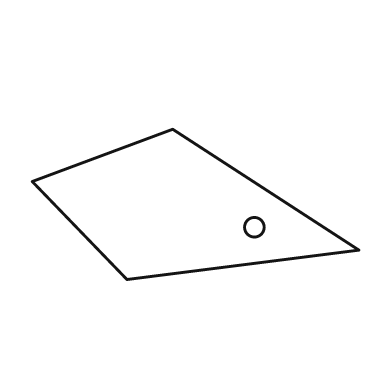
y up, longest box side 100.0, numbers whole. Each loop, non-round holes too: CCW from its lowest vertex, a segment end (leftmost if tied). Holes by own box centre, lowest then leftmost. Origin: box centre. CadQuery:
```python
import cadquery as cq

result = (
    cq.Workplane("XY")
    .moveTo(-21.0, -23.0)
    .lineTo(50.0, -14.0)
    .lineTo(-7.0, 23.0)
    .lineTo(-50.0, 7.0)
    .close()
    .moveTo(18.0, -7.0)
    .circle(3.0)
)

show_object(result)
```